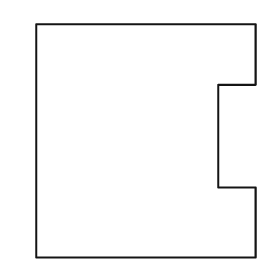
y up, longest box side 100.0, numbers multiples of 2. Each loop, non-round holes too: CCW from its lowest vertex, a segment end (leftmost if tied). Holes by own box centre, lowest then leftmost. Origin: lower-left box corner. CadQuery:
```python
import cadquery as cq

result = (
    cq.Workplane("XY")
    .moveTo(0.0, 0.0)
    .lineTo(94.0, 0.0)
    .lineTo(94.0, 30.0)
    .lineTo(78.0, 30.0)
    .lineTo(78.0, 74.0)
    .lineTo(94.0, 74.0)
    .lineTo(94.0, 100.0)
    .lineTo(0.0, 100.0)
    .close()
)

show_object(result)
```